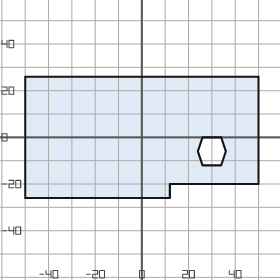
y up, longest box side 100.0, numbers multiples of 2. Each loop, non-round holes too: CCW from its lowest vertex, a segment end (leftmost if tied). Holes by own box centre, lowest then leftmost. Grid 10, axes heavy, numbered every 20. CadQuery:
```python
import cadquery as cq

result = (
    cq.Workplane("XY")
    .moveTo(-50.0, -26.0)
    .lineTo(12.0, -26.0)
    .lineTo(12.0, -20.0)
    .lineTo(50.0, -20.0)
    .lineTo(50.0, 26.0)
    .lineTo(-50.0, 26.0)
    .close()
    .moveTo(26.0, -12.0)
    .lineTo(34.0, -12.0)
    .lineTo(36.0, -6.0)
    .lineTo(34.0, 0.0)
    .lineTo(26.0, 0.0)
    .lineTo(24.0, -6.0)
    .close()
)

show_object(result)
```